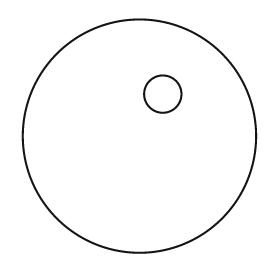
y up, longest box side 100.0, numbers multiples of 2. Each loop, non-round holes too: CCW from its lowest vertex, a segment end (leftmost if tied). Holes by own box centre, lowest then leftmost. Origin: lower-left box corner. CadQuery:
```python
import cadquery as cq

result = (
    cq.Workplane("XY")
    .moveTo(50.0, 50.0)
    .circle(50.0)
    .moveTo(60.0, 68.0)
    .circle(8.0)
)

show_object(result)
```